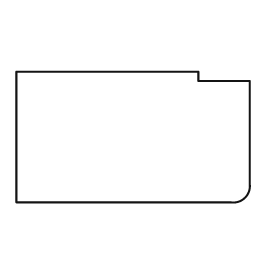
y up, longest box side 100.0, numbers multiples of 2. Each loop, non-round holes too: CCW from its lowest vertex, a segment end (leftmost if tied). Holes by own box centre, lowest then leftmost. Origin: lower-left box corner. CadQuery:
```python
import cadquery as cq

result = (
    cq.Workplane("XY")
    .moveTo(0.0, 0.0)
    .lineTo(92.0, 0.0)
    .threePointArc((98.0, 2.0), (100.0, 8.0))
    .lineTo(100.0, 52.0)
    .lineTo(78.0, 52.0)
    .lineTo(78.0, 56.0)
    .lineTo(0.0, 56.0)
    .close()
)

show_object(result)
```